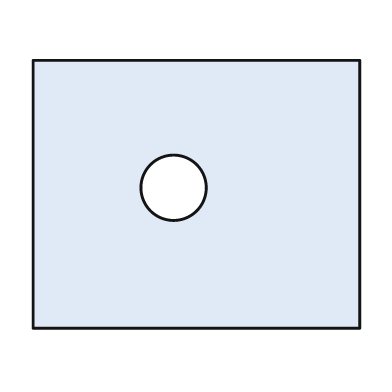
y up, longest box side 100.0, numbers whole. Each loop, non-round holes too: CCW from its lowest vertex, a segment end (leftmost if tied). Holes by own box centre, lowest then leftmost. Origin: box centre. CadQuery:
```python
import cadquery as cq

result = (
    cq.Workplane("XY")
    .moveTo(-50.0, -41.0)
    .lineTo(50.0, -41.0)
    .lineTo(50.0, 41.0)
    .lineTo(-50.0, 41.0)
    .close()
    .moveTo(-7.0, 2.0)
    .circle(10.0)
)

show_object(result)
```